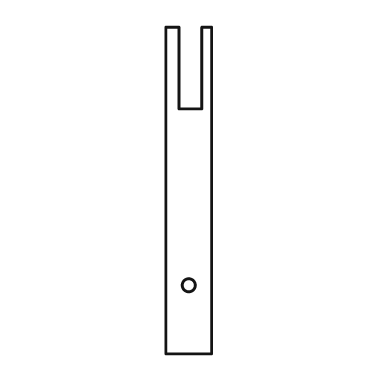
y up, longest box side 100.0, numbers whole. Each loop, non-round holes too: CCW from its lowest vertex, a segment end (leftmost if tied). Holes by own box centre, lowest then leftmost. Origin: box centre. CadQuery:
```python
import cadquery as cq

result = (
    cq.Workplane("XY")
    .moveTo(-7.0, -50.0)
    .lineTo(7.0, -50.0)
    .lineTo(7.0, 50.0)
    .lineTo(4.0, 50.0)
    .lineTo(4.0, 25.0)
    .lineTo(-3.0, 25.0)
    .lineTo(-3.0, 50.0)
    .lineTo(-7.0, 50.0)
    .close()
    .moveTo(0.0, -29.0)
    .circle(2.0)
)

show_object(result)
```